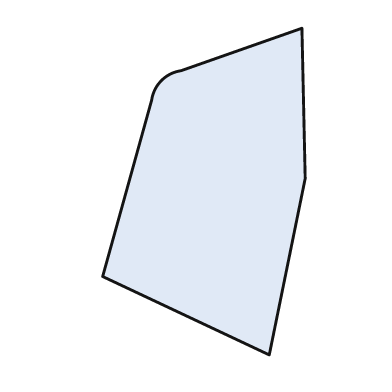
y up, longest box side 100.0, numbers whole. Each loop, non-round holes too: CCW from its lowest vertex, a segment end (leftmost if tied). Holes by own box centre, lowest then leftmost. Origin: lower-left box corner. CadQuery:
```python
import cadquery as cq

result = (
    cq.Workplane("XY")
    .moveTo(51.0, 0.0)
    .lineTo(62.0, 54.0)
    .lineTo(61.0, 100.0)
    .lineTo(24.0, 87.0)
    .threePointArc((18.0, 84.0), (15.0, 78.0))
    .lineTo(0.0, 24.0)
    .close()
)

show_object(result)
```